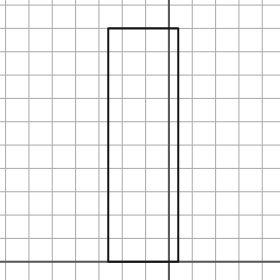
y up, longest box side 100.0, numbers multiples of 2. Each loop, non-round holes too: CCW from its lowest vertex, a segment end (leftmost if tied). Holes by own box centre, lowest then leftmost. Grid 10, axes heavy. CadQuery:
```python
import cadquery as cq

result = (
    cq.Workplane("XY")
    .moveTo(-26.0, 0.0)
    .lineTo(4.0, 0.0)
    .lineTo(4.0, 100.0)
    .lineTo(-26.0, 100.0)
    .close()
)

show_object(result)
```